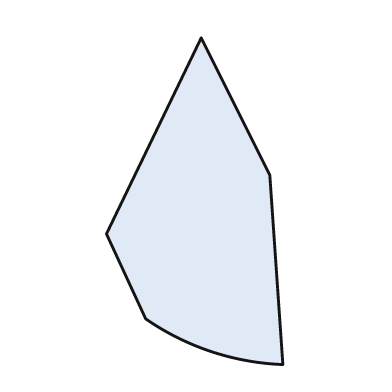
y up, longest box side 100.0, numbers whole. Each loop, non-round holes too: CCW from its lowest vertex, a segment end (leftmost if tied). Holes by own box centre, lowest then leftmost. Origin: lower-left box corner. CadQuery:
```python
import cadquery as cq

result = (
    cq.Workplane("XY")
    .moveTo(54.0, 0.0)
    .lineTo(50.0, 58.0)
    .lineTo(29.0, 100.0)
    .lineTo(0.0, 40.0)
    .lineTo(12.0, 14.0)
    .threePointArc((32.0, 4.0), (54.0, 0.0))
    .close()
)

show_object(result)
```